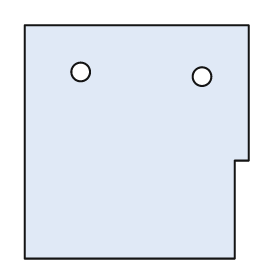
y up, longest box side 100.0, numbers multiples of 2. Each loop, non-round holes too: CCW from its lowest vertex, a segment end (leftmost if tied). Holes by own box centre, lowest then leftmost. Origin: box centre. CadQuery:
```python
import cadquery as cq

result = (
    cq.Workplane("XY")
    .moveTo(-48.0, -50.0)
    .lineTo(42.0, -50.0)
    .lineTo(42.0, -8.0)
    .lineTo(48.0, -8.0)
    .lineTo(48.0, 50.0)
    .lineTo(-48.0, 50.0)
    .close()
    .moveTo(28.0, 28.0)
    .circle(4.0)
    .moveTo(-24.0, 30.0)
    .circle(4.0)
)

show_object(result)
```